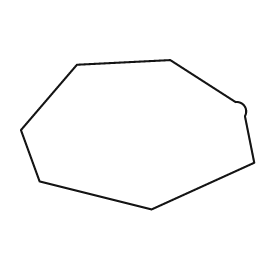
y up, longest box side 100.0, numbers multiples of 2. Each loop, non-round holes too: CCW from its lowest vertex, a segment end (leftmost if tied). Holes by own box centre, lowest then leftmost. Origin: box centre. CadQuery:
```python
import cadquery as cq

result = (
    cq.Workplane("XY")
    .moveTo(6.0, -32.0)
    .lineTo(50.0, -12.0)
    .lineTo(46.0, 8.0)
    .threePointArc((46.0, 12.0), (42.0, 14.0))
    .lineTo(14.0, 32.0)
    .lineTo(-26.0, 30.0)
    .lineTo(-50.0, 2.0)
    .lineTo(-42.0, -20.0)
    .close()
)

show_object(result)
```